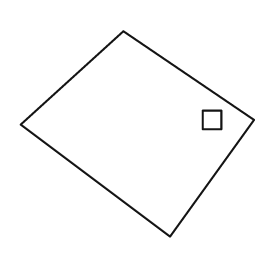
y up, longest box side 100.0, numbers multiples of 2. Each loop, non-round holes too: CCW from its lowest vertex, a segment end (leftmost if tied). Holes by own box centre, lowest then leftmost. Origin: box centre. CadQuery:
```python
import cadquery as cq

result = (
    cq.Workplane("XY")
    .moveTo(14.0, -44.0)
    .lineTo(50.0, 6.0)
    .lineTo(-6.0, 44.0)
    .lineTo(-50.0, 4.0)
    .close()
    .moveTo(28.0, 2.0)
    .lineTo(36.0, 2.0)
    .lineTo(36.0, 10.0)
    .lineTo(28.0, 10.0)
    .close()
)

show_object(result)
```